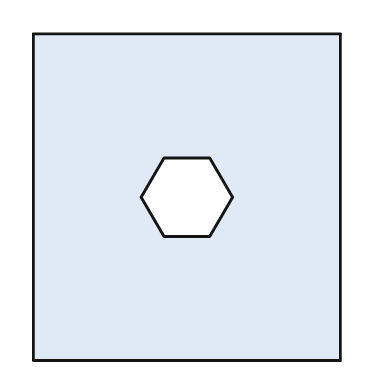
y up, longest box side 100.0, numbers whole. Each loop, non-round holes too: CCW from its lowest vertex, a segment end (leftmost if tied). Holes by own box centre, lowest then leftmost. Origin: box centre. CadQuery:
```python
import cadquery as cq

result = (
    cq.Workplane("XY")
    .moveTo(-47.0, -50.0)
    .lineTo(47.0, -50.0)
    .lineTo(47.0, 50.0)
    .lineTo(-47.0, 50.0)
    .close()
    .moveTo(-7.0, -12.0)
    .lineTo(7.0, -12.0)
    .lineTo(14.0, 0.0)
    .lineTo(7.0, 12.0)
    .lineTo(-7.0, 12.0)
    .lineTo(-14.0, 0.0)
    .close()
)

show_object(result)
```